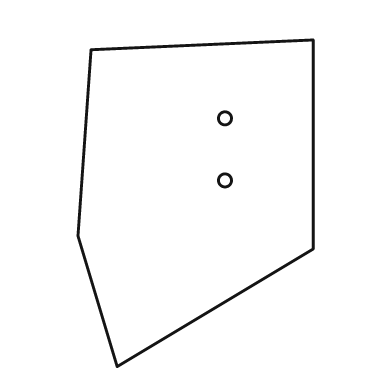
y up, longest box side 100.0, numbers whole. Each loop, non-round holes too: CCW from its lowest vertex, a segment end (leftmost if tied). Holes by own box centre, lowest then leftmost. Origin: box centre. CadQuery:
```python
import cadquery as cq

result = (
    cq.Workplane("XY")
    .moveTo(-24.0, -50.0)
    .lineTo(36.0, -14.0)
    .lineTo(36.0, 50.0)
    .lineTo(-32.0, 47.0)
    .lineTo(-36.0, -10.0)
    .close()
    .moveTo(9.0, 7.0)
    .circle(2.0)
    .moveTo(9.0, 26.0)
    .circle(2.0)
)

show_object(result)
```